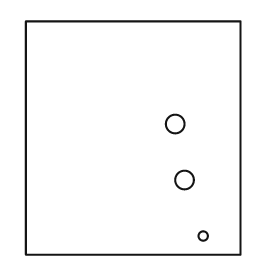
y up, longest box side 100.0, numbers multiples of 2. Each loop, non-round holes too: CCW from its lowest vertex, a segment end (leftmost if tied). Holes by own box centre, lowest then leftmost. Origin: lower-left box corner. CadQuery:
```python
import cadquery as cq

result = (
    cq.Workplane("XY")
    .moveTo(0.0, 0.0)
    .lineTo(92.0, 0.0)
    .lineTo(92.0, 100.0)
    .lineTo(0.0, 100.0)
    .close()
    .moveTo(76.0, 8.0)
    .circle(2.0)
    .moveTo(68.0, 32.0)
    .circle(4.0)
    .moveTo(64.0, 56.0)
    .circle(4.0)
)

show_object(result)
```